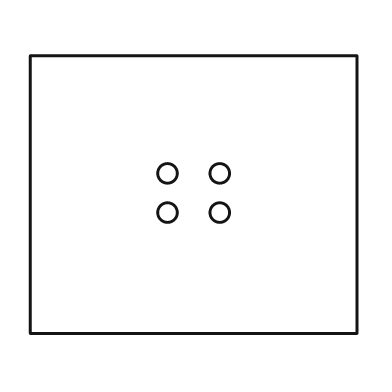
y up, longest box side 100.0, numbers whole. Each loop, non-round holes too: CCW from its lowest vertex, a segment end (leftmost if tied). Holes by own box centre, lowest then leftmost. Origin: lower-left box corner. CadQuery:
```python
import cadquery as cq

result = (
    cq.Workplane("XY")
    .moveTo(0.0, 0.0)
    .lineTo(100.0, 0.0)
    .lineTo(100.0, 85.0)
    .lineTo(0.0, 85.0)
    .close()
    .moveTo(42.0, 37.0)
    .circle(3.0)
    .moveTo(58.0, 37.0)
    .circle(3.0)
    .moveTo(42.0, 49.0)
    .circle(3.0)
    .moveTo(58.0, 49.0)
    .circle(3.0)
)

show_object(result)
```